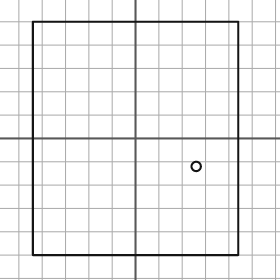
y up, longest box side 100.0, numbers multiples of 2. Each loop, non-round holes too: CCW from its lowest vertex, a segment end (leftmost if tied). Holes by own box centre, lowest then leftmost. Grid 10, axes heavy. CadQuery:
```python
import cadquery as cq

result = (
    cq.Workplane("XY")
    .moveTo(-44.0, -50.0)
    .lineTo(44.0, -50.0)
    .lineTo(44.0, 50.0)
    .lineTo(-44.0, 50.0)
    .close()
    .moveTo(26.0, -12.0)
    .circle(2.0)
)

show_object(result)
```